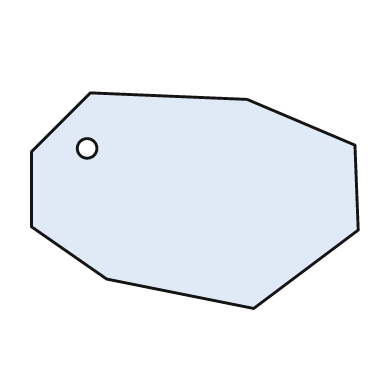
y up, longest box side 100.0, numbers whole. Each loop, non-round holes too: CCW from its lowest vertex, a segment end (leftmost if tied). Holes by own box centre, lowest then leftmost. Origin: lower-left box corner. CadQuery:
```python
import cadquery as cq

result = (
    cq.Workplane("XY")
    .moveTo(68.0, 0.0)
    .lineTo(100.0, 24.0)
    .lineTo(99.0, 50.0)
    .lineTo(66.0, 64.0)
    .lineTo(18.0, 66.0)
    .lineTo(0.0, 48.0)
    .lineTo(0.0, 25.0)
    .lineTo(23.0, 9.0)
    .close()
    .moveTo(17.0, 49.0)
    .circle(3.0)
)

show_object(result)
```